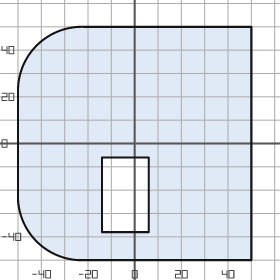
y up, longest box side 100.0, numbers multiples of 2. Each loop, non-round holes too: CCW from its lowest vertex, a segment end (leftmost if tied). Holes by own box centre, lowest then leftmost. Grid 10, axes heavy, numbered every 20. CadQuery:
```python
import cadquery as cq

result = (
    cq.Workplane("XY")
    .moveTo(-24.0, -50.0)
    .lineTo(50.0, -50.0)
    .lineTo(50.0, 50.0)
    .lineTo(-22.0, 50.0)
    .threePointArc((-42.0, 42.0), (-50.0, 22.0))
    .lineTo(-50.0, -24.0)
    .threePointArc((-42.0, -42.0), (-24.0, -50.0))
    .close()
    .moveTo(-14.0, -38.0)
    .lineTo(6.0, -38.0)
    .lineTo(6.0, -6.0)
    .lineTo(-14.0, -6.0)
    .close()
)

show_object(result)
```